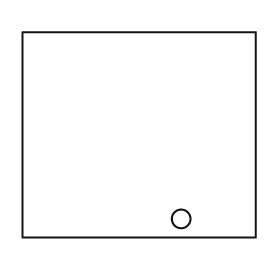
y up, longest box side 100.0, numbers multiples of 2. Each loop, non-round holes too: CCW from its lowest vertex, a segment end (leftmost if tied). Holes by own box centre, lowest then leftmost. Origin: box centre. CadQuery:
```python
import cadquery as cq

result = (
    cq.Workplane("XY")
    .moveTo(-50.0, -44.0)
    .lineTo(50.0, -44.0)
    .lineTo(50.0, 44.0)
    .lineTo(-50.0, 44.0)
    .close()
    .moveTo(18.0, -36.0)
    .circle(4.0)
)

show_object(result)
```